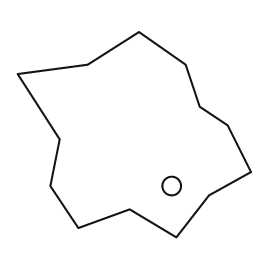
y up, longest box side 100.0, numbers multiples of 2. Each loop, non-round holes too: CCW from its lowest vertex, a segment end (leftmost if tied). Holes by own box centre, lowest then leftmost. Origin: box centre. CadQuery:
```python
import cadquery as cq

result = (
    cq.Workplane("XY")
    .moveTo(18.0, -44.0)
    .lineTo(32.0, -26.0)
    .lineTo(50.0, -16.0)
    .lineTo(40.0, 4.0)
    .lineTo(28.0, 12.0)
    .lineTo(22.0, 30.0)
    .lineTo(2.0, 44.0)
    .lineTo(-20.0, 30.0)
    .lineTo(-50.0, 26.0)
    .lineTo(-32.0, -2.0)
    .lineTo(-36.0, -22.0)
    .lineTo(-24.0, -40.0)
    .lineTo(-2.0, -32.0)
    .close()
    .moveTo(16.0, -22.0)
    .circle(4.0)
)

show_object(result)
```